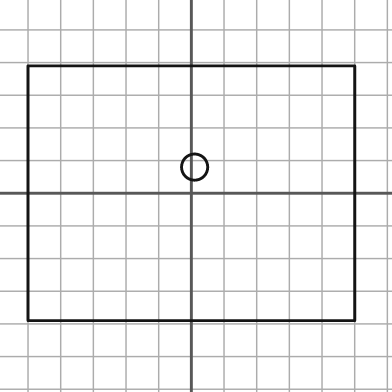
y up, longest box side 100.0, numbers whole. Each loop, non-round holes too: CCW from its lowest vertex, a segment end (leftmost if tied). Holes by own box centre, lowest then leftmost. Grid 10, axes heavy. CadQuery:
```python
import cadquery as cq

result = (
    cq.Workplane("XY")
    .moveTo(-50.0, -39.0)
    .lineTo(50.0, -39.0)
    .lineTo(50.0, 39.0)
    .lineTo(-50.0, 39.0)
    .close()
    .moveTo(1.0, 8.0)
    .circle(4.0)
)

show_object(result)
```